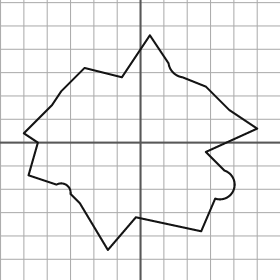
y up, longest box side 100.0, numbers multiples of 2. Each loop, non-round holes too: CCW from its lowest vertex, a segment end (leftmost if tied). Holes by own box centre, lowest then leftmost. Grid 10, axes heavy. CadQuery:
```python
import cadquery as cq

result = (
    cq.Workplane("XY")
    .moveTo(-14.0, -46.0)
    .lineTo(-2.0, -32.0)
    .lineTo(26.0, -38.0)
    .lineTo(32.0, -24.0)
    .threePointArc((40.0, -20.0), (36.0, -12.0))
    .lineTo(28.0, -4.0)
    .lineTo(50.0, 6.0)
    .lineTo(38.0, 14.0)
    .lineTo(28.0, 24.0)
    .lineTo(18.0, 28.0)
    .threePointArc((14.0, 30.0), (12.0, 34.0))
    .lineTo(4.0, 46.0)
    .lineTo(-8.0, 28.0)
    .lineTo(-24.0, 32.0)
    .lineTo(-34.0, 22.0)
    .lineTo(-38.0, 16.0)
    .lineTo(-50.0, 4.0)
    .lineTo(-44.0, 0.0)
    .lineTo(-48.0, -14.0)
    .lineTo(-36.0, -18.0)
    .threePointArc((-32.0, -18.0), (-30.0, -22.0))
    .lineTo(-26.0, -26.0)
    .close()
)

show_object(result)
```